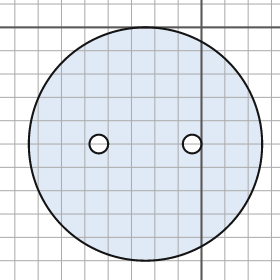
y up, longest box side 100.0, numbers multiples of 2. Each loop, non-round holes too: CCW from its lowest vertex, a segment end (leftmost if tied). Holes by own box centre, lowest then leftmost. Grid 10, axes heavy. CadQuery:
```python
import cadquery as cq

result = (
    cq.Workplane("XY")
    .moveTo(-24.0, -50.0)
    .circle(50.0)
    .moveTo(-44.0, -50.0)
    .circle(4.0)
    .moveTo(-4.0, -50.0)
    .circle(4.0)
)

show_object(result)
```